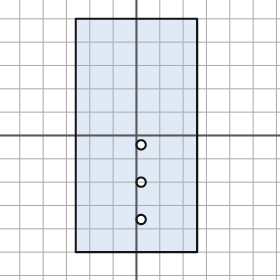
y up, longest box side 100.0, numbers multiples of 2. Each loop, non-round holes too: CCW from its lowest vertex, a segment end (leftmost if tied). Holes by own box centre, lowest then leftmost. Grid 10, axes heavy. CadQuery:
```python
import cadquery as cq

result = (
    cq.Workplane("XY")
    .moveTo(-26.0, -50.0)
    .lineTo(26.0, -50.0)
    .lineTo(26.0, 50.0)
    .lineTo(-26.0, 50.0)
    .close()
    .moveTo(2.0, -36.0)
    .circle(2.0)
    .moveTo(2.0, -20.0)
    .circle(2.0)
    .moveTo(2.0, -4.0)
    .circle(2.0)
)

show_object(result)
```